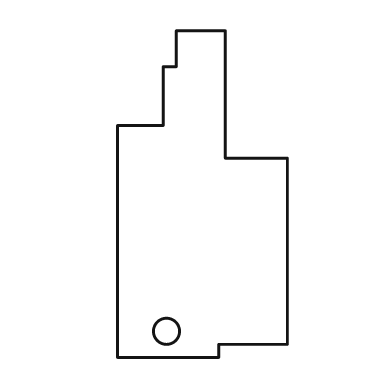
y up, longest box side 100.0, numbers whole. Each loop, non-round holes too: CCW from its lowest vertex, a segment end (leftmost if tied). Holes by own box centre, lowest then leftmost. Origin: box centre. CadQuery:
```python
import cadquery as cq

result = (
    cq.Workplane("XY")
    .moveTo(-26.0, -50.0)
    .lineTo(5.0, -50.0)
    .lineTo(5.0, -46.0)
    .lineTo(26.0, -46.0)
    .lineTo(26.0, 11.0)
    .lineTo(7.0, 11.0)
    .lineTo(7.0, 50.0)
    .lineTo(-8.0, 50.0)
    .lineTo(-8.0, 39.0)
    .lineTo(-12.0, 39.0)
    .lineTo(-12.0, 21.0)
    .lineTo(-26.0, 21.0)
    .close()
    .moveTo(-11.0, -42.0)
    .circle(4.0)
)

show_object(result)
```